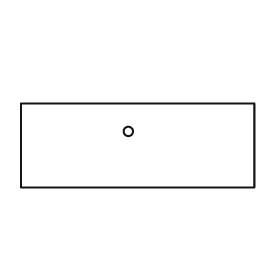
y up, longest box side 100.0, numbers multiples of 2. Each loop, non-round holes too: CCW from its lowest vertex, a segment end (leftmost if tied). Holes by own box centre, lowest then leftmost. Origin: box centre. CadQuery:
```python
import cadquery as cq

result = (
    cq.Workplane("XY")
    .moveTo(-50.0, -18.0)
    .lineTo(50.0, -18.0)
    .lineTo(50.0, 18.0)
    .lineTo(-50.0, 18.0)
    .close()
    .moveTo(-4.0, 6.0)
    .circle(2.0)
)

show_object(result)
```